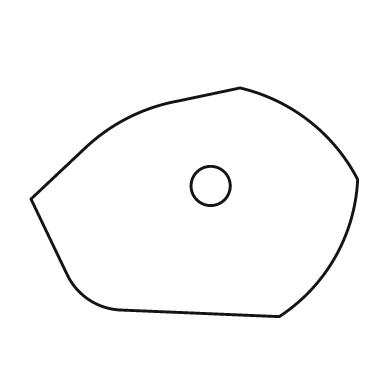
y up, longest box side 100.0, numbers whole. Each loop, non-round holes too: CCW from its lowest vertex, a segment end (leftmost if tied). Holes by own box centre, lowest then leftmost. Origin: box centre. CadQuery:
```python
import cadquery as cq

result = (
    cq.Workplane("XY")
    .moveTo(26.0, -35.0)
    .threePointArc((43.0, -17.0), (50.0, 7.0))
    .threePointArc((35.0, 25.0), (14.0, 35.0))
    .lineTo(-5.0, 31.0)
    .threePointArc((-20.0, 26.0), (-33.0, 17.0))
    .lineTo(-50.0, 1.0)
    .lineTo(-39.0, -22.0)
    .threePointArc((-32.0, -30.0), (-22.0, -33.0))
    .close()
    .moveTo(5.0, 5.0)
    .circle(6.0)
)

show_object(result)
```